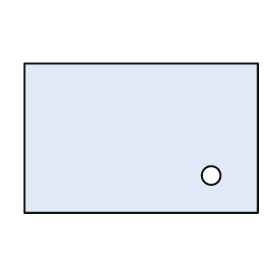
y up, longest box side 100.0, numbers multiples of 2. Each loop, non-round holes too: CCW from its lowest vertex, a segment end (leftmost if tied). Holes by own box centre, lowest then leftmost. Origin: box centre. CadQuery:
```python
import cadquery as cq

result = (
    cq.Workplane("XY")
    .moveTo(-50.0, -32.0)
    .lineTo(50.0, -32.0)
    .lineTo(50.0, 32.0)
    .lineTo(-50.0, 32.0)
    .close()
    .moveTo(30.0, -16.0)
    .circle(4.0)
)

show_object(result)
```